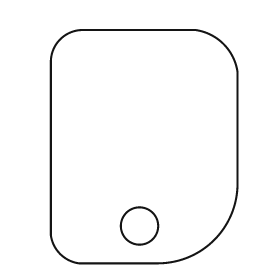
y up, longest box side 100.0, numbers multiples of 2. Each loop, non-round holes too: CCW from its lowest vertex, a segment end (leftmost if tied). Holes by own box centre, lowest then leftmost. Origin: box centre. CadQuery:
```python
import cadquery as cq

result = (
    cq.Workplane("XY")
    .moveTo(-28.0, -50.0)
    .lineTo(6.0, -50.0)
    .threePointArc((30.0, -40.0), (40.0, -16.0))
    .lineTo(40.0, 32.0)
    .threePointArc((34.0, 44.0), (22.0, 50.0))
    .lineTo(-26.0, 50.0)
    .threePointArc((-36.0, 46.0), (-40.0, 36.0))
    .lineTo(-40.0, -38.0)
    .threePointArc((-36.0, -46.0), (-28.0, -50.0))
    .close()
    .moveTo(-2.0, -34.0)
    .circle(8.0)
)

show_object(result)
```